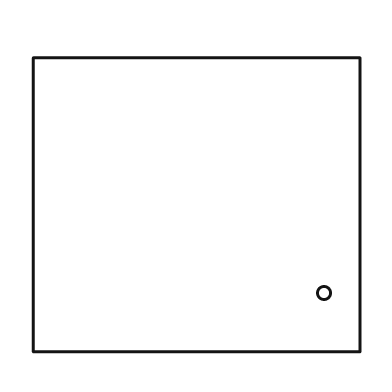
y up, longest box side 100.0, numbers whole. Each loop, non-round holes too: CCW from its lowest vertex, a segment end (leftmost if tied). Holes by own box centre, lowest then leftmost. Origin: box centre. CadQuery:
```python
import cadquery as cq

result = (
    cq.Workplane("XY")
    .moveTo(-50.0, -45.0)
    .lineTo(50.0, -45.0)
    .lineTo(50.0, 45.0)
    .lineTo(-50.0, 45.0)
    .close()
    .moveTo(39.0, -27.0)
    .circle(2.0)
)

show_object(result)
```